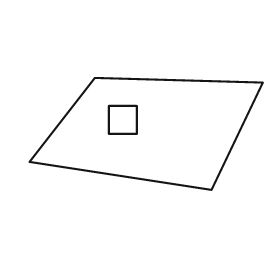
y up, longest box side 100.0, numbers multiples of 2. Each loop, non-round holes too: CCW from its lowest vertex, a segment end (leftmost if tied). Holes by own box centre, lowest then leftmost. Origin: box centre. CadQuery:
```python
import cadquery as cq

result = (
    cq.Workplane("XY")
    .moveTo(28.0, -24.0)
    .lineTo(50.0, 22.0)
    .lineTo(-22.0, 24.0)
    .lineTo(-50.0, -12.0)
    .close()
    .moveTo(-16.0, 0.0)
    .lineTo(-4.0, 0.0)
    .lineTo(-4.0, 12.0)
    .lineTo(-16.0, 12.0)
    .close()
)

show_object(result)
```